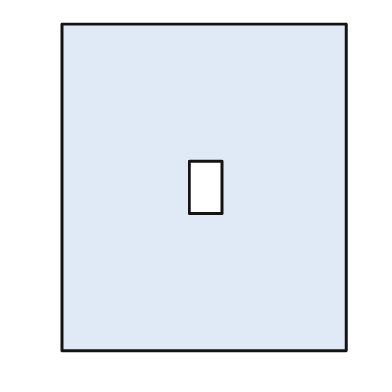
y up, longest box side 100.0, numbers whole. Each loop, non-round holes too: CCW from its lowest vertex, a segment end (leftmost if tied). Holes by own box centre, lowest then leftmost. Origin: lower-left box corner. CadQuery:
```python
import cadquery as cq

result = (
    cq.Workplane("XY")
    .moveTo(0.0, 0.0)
    .lineTo(87.0, 0.0)
    .lineTo(87.0, 100.0)
    .lineTo(0.0, 100.0)
    .close()
    .moveTo(39.0, 42.0)
    .lineTo(49.0, 42.0)
    .lineTo(49.0, 58.0)
    .lineTo(39.0, 58.0)
    .close()
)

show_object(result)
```